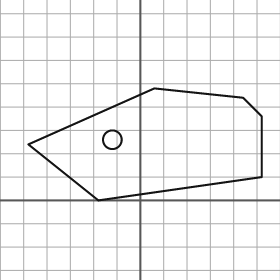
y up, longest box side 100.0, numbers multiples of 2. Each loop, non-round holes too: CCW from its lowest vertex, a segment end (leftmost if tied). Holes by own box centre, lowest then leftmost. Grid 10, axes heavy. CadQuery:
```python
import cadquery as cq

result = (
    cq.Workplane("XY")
    .moveTo(-18.0, 0.0)
    .lineTo(52.0, 10.0)
    .lineTo(52.0, 36.0)
    .lineTo(44.0, 44.0)
    .lineTo(6.0, 48.0)
    .lineTo(-48.0, 24.0)
    .close()
    .moveTo(-12.0, 26.0)
    .circle(4.0)
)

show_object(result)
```